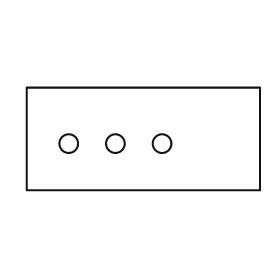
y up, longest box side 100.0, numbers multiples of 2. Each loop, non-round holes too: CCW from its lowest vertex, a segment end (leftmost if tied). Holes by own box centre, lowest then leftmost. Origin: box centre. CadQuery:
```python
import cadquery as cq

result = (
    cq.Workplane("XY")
    .moveTo(-50.0, -22.0)
    .lineTo(50.0, -22.0)
    .lineTo(50.0, 22.0)
    .lineTo(-50.0, 22.0)
    .close()
    .moveTo(-32.0, -2.0)
    .circle(4.0)
    .moveTo(-12.0, -2.0)
    .circle(4.0)
    .moveTo(8.0, -2.0)
    .circle(4.0)
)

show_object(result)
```